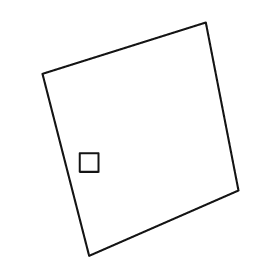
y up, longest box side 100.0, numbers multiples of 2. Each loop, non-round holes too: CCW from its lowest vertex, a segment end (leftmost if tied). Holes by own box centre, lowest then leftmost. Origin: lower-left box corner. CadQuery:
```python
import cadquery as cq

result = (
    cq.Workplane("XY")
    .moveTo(20.0, 0.0)
    .lineTo(84.0, 28.0)
    .lineTo(70.0, 100.0)
    .lineTo(0.0, 78.0)
    .close()
    .moveTo(16.0, 36.0)
    .lineTo(24.0, 36.0)
    .lineTo(24.0, 44.0)
    .lineTo(16.0, 44.0)
    .close()
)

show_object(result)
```